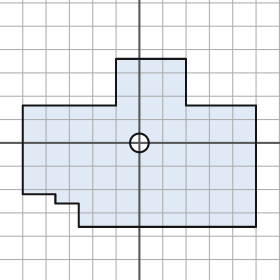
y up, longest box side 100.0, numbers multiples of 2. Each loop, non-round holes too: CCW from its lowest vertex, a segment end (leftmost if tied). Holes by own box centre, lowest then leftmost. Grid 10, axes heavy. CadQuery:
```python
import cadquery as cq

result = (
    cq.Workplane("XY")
    .moveTo(-26.0, -36.0)
    .lineTo(50.0, -36.0)
    .lineTo(50.0, 16.0)
    .lineTo(20.0, 16.0)
    .lineTo(20.0, 36.0)
    .lineTo(-10.0, 36.0)
    .lineTo(-10.0, 16.0)
    .lineTo(-50.0, 16.0)
    .lineTo(-50.0, -22.0)
    .lineTo(-36.0, -22.0)
    .lineTo(-36.0, -26.0)
    .lineTo(-26.0, -26.0)
    .close()
    .moveTo(0.0, 0.0)
    .circle(4.0)
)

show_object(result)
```